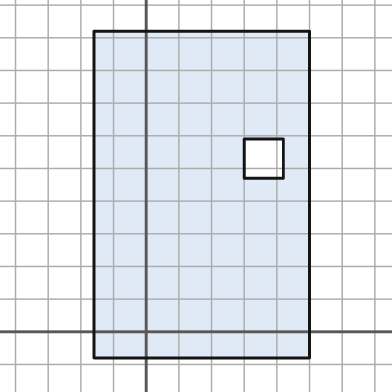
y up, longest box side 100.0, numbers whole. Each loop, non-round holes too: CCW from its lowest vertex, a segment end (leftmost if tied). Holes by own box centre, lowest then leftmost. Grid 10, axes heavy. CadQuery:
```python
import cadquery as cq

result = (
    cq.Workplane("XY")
    .moveTo(-16.0, -8.0)
    .lineTo(50.0, -8.0)
    .lineTo(50.0, 92.0)
    .lineTo(-16.0, 92.0)
    .close()
    .moveTo(30.0, 47.0)
    .lineTo(42.0, 47.0)
    .lineTo(42.0, 59.0)
    .lineTo(30.0, 59.0)
    .close()
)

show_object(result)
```